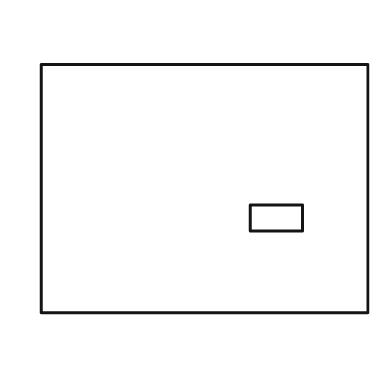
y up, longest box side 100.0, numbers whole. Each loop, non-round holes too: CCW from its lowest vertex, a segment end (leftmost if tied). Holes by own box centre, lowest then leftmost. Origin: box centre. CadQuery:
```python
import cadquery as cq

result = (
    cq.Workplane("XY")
    .moveTo(-50.0, -38.0)
    .lineTo(50.0, -38.0)
    .lineTo(50.0, 38.0)
    .lineTo(-50.0, 38.0)
    .close()
    .moveTo(14.0, -13.0)
    .lineTo(30.0, -13.0)
    .lineTo(30.0, -5.0)
    .lineTo(14.0, -5.0)
    .close()
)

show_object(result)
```